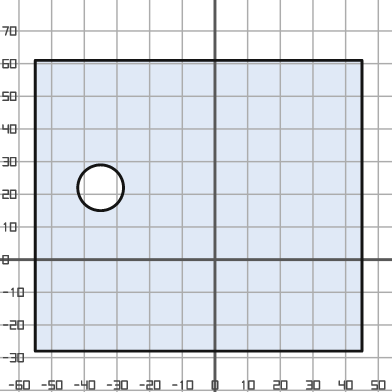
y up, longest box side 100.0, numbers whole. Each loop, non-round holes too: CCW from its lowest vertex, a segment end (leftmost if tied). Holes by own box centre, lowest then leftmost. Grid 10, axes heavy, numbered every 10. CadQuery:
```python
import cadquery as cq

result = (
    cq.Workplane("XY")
    .moveTo(-55.0, -28.0)
    .lineTo(45.0, -28.0)
    .lineTo(45.0, 61.0)
    .lineTo(-55.0, 61.0)
    .close()
    .moveTo(-35.0, 22.0)
    .circle(7.0)
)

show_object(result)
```